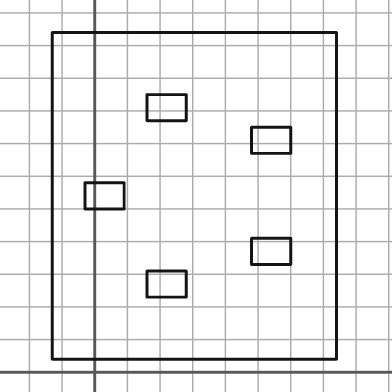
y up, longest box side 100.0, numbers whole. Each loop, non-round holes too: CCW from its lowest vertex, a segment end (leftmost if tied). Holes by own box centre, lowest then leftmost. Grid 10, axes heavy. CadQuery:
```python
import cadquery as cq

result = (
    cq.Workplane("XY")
    .moveTo(-13.0, 4.0)
    .lineTo(74.0, 4.0)
    .lineTo(74.0, 104.0)
    .lineTo(-13.0, 104.0)
    .close()
    .moveTo(16.0, 23.0)
    .lineTo(28.0, 23.0)
    .lineTo(28.0, 31.0)
    .lineTo(16.0, 31.0)
    .close()
    .moveTo(48.0, 33.0)
    .lineTo(60.0, 33.0)
    .lineTo(60.0, 41.0)
    .lineTo(48.0, 41.0)
    .close()
    .moveTo(-3.0, 50.0)
    .lineTo(9.0, 50.0)
    .lineTo(9.0, 58.0)
    .lineTo(-3.0, 58.0)
    .close()
    .moveTo(48.0, 67.0)
    .lineTo(60.0, 67.0)
    .lineTo(60.0, 75.0)
    .lineTo(48.0, 75.0)
    .close()
    .moveTo(16.0, 77.0)
    .lineTo(28.0, 77.0)
    .lineTo(28.0, 85.0)
    .lineTo(16.0, 85.0)
    .close()
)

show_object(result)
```